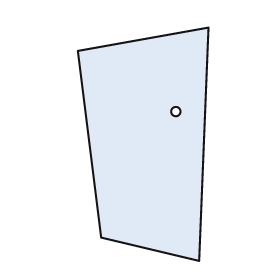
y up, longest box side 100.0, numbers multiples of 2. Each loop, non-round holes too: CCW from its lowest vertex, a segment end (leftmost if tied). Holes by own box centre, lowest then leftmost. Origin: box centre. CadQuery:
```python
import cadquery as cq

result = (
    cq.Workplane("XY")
    .moveTo(24.0, -50.0)
    .lineTo(28.0, 50.0)
    .lineTo(-28.0, 40.0)
    .lineTo(-18.0, -40.0)
    .close()
    .moveTo(14.0, 14.0)
    .circle(2.0)
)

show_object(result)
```